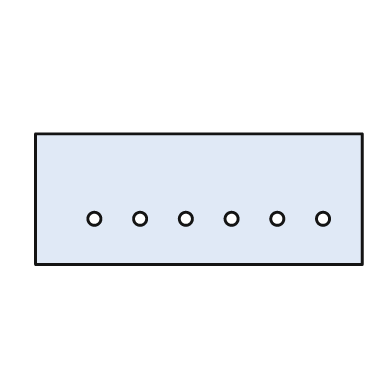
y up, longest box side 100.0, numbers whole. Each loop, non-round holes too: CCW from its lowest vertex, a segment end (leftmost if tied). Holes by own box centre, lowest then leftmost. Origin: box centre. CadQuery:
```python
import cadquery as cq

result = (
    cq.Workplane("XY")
    .moveTo(-50.0, -20.0)
    .lineTo(50.0, -20.0)
    .lineTo(50.0, 20.0)
    .lineTo(-50.0, 20.0)
    .close()
    .moveTo(-32.0, -6.0)
    .circle(2.0)
    .moveTo(-18.0, -6.0)
    .circle(2.0)
    .moveTo(-4.0, -6.0)
    .circle(2.0)
    .moveTo(10.0, -6.0)
    .circle(2.0)
    .moveTo(24.0, -6.0)
    .circle(2.0)
    .moveTo(38.0, -6.0)
    .circle(2.0)
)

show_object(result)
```